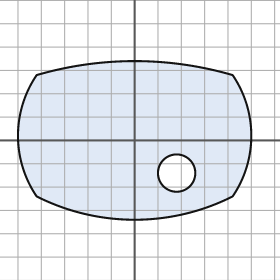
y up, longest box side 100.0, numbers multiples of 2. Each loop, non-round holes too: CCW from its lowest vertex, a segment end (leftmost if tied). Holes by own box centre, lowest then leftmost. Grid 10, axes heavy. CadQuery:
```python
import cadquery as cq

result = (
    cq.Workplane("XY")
    .moveTo(-42.0, -24.0)
    .threePointArc((0.0, -34.0), (42.0, -24.0))
    .threePointArc((50.0, 2.0), (42.0, 28.0))
    .threePointArc((0.0, 34.0), (-42.0, 28.0))
    .threePointArc((-50.0, 2.0), (-42.0, -24.0))
    .close()
    .moveTo(18.0, -14.0)
    .circle(8.0)
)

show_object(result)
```